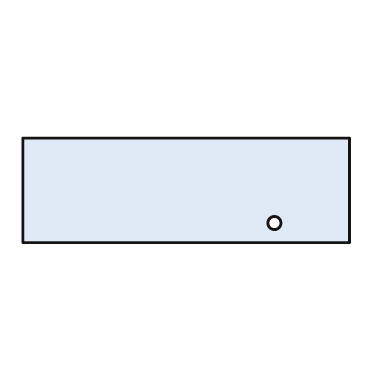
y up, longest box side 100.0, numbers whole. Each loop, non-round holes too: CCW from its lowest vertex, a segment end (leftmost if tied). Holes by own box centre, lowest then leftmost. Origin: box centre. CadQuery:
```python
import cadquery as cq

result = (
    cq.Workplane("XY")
    .moveTo(-50.0, -16.0)
    .lineTo(50.0, -16.0)
    .lineTo(50.0, 16.0)
    .lineTo(-50.0, 16.0)
    .close()
    .moveTo(27.0, -10.0)
    .circle(2.0)
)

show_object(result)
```